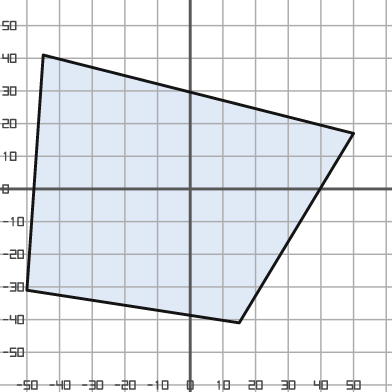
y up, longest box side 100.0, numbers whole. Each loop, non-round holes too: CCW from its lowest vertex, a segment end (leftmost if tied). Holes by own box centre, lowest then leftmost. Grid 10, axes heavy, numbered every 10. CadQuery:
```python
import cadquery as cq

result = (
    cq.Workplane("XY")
    .moveTo(15.0, -41.0)
    .lineTo(50.0, 17.0)
    .lineTo(-45.0, 41.0)
    .lineTo(-50.0, -31.0)
    .close()
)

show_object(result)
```